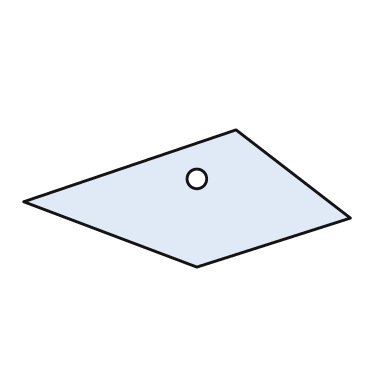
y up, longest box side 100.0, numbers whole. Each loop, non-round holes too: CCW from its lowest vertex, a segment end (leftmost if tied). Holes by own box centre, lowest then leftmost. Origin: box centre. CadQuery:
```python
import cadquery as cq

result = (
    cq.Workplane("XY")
    .moveTo(3.0, -21.0)
    .lineTo(50.0, -6.0)
    .lineTo(15.0, 21.0)
    .lineTo(-50.0, -1.0)
    .close()
    .moveTo(3.0, 6.0)
    .circle(3.0)
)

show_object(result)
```